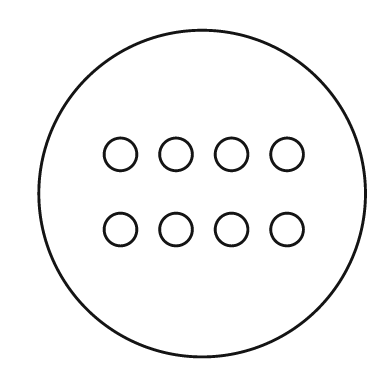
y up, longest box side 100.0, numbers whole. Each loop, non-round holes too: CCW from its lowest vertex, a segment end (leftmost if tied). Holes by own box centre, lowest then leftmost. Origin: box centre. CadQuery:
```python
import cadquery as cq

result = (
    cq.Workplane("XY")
    .moveTo(0.0, 0.0)
    .circle(50.0)
    .moveTo(-25.0, -11.0)
    .circle(5.0)
    .moveTo(-8.0, -11.0)
    .circle(5.0)
    .moveTo(9.0, -11.0)
    .circle(5.0)
    .moveTo(26.0, -11.0)
    .circle(5.0)
    .moveTo(-25.0, 12.0)
    .circle(5.0)
    .moveTo(-8.0, 12.0)
    .circle(5.0)
    .moveTo(9.0, 12.0)
    .circle(5.0)
    .moveTo(26.0, 12.0)
    .circle(5.0)
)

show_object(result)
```